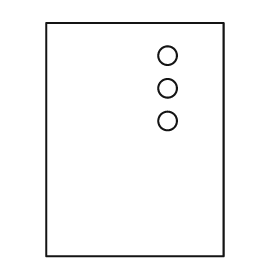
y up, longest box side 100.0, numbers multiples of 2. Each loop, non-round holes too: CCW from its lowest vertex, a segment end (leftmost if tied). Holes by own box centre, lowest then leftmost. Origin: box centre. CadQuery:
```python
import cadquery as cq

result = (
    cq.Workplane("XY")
    .moveTo(-38.0, -50.0)
    .lineTo(38.0, -50.0)
    .lineTo(38.0, 50.0)
    .lineTo(-38.0, 50.0)
    .close()
    .moveTo(14.0, 8.0)
    .circle(4.0)
    .moveTo(14.0, 22.0)
    .circle(4.0)
    .moveTo(14.0, 36.0)
    .circle(4.0)
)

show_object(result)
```